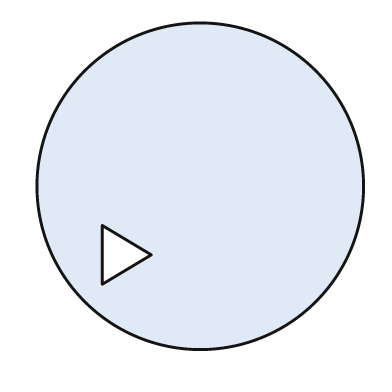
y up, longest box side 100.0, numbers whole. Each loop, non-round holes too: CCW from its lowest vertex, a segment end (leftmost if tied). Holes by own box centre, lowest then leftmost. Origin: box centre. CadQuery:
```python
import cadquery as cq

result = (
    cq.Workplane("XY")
    .moveTo(0.0, 0.0)
    .circle(50.0)
    .moveTo(-30.0, -30.0)
    .lineTo(-15.0, -21.0)
    .lineTo(-30.0, -12.0)
    .close()
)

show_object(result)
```